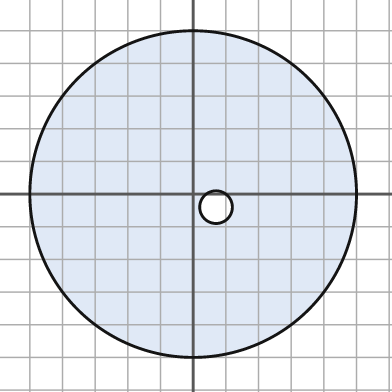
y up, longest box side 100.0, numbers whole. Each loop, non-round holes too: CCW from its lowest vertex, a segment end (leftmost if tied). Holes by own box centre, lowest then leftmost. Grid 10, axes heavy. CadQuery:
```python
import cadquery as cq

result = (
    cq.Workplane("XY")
    .moveTo(0.0, 0.0)
    .circle(50.0)
    .moveTo(7.0, -4.0)
    .circle(5.0)
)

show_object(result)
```